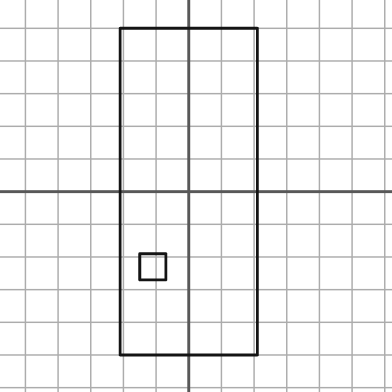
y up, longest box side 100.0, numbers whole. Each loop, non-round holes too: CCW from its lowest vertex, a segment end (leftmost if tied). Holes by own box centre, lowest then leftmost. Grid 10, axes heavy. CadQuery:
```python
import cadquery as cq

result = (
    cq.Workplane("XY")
    .moveTo(-21.0, -50.0)
    .lineTo(21.0, -50.0)
    .lineTo(21.0, 50.0)
    .lineTo(-21.0, 50.0)
    .close()
    .moveTo(-15.0, -27.0)
    .lineTo(-7.0, -27.0)
    .lineTo(-7.0, -19.0)
    .lineTo(-15.0, -19.0)
    .close()
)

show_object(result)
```